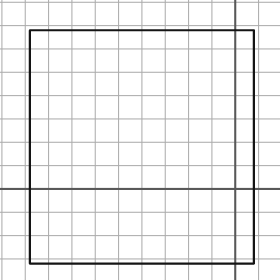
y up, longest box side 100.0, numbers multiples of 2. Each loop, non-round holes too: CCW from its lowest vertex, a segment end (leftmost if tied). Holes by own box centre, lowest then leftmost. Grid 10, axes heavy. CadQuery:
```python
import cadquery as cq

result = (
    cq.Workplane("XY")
    .moveTo(-88.0, -32.0)
    .lineTo(8.0, -32.0)
    .lineTo(8.0, 68.0)
    .lineTo(-88.0, 68.0)
    .close()
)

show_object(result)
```